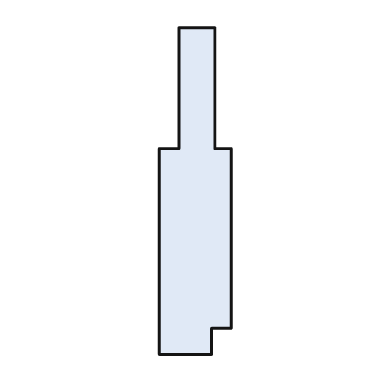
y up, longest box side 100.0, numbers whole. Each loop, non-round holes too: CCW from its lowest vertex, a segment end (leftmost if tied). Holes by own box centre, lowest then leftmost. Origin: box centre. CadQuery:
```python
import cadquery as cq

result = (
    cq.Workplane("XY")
    .moveTo(-11.0, -50.0)
    .lineTo(5.0, -50.0)
    .lineTo(5.0, -42.0)
    .lineTo(11.0, -42.0)
    .lineTo(11.0, 13.0)
    .lineTo(6.0, 13.0)
    .lineTo(6.0, 50.0)
    .lineTo(-5.0, 50.0)
    .lineTo(-5.0, 13.0)
    .lineTo(-11.0, 13.0)
    .close()
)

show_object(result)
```